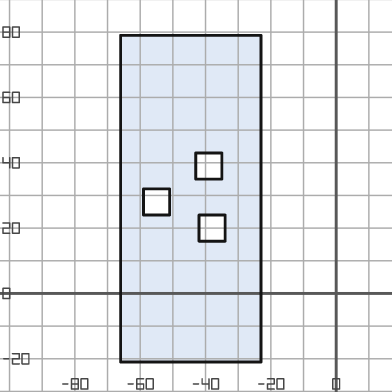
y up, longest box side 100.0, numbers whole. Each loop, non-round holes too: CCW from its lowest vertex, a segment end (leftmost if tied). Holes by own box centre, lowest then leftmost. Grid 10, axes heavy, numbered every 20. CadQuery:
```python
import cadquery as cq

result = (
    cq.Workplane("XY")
    .moveTo(-66.0, -21.0)
    .lineTo(-23.0, -21.0)
    .lineTo(-23.0, 79.0)
    .lineTo(-66.0, 79.0)
    .close()
    .moveTo(-42.0, 16.0)
    .lineTo(-34.0, 16.0)
    .lineTo(-34.0, 24.0)
    .lineTo(-42.0, 24.0)
    .close()
    .moveTo(-59.0, 24.0)
    .lineTo(-51.0, 24.0)
    .lineTo(-51.0, 32.0)
    .lineTo(-59.0, 32.0)
    .close()
    .moveTo(-43.0, 35.0)
    .lineTo(-35.0, 35.0)
    .lineTo(-35.0, 43.0)
    .lineTo(-43.0, 43.0)
    .close()
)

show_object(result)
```